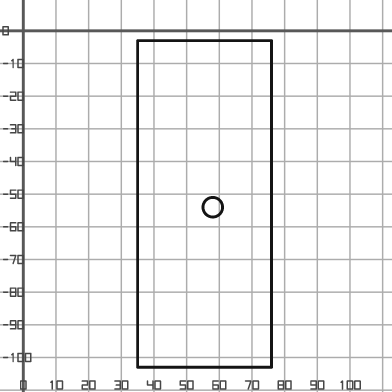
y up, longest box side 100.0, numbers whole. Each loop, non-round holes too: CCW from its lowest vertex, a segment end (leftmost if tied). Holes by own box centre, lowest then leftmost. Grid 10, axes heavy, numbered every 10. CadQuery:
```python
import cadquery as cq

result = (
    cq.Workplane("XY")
    .moveTo(35.0, -103.0)
    .lineTo(76.0, -103.0)
    .lineTo(76.0, -3.0)
    .lineTo(35.0, -3.0)
    .close()
    .moveTo(58.0, -54.0)
    .circle(3.0)
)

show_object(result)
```